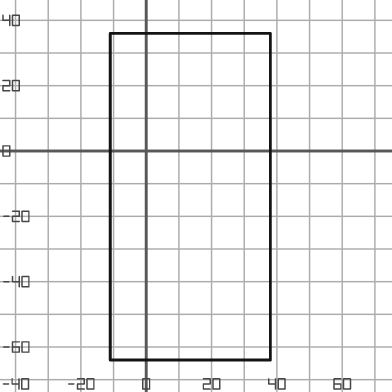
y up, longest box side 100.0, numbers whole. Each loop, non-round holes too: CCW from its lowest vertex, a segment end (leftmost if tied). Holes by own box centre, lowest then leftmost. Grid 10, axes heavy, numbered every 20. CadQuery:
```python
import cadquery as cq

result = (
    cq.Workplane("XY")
    .moveTo(-11.0, -64.0)
    .lineTo(38.0, -64.0)
    .lineTo(38.0, 36.0)
    .lineTo(-11.0, 36.0)
    .close()
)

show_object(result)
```